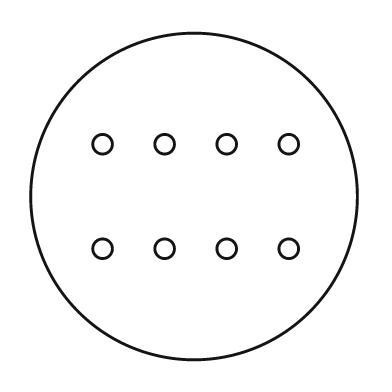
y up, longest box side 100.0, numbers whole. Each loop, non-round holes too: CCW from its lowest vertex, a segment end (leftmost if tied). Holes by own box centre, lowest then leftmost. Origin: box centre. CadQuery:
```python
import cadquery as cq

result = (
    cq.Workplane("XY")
    .moveTo(0.0, 0.0)
    .circle(50.0)
    .moveTo(-28.0, -16.0)
    .circle(3.0)
    .moveTo(-9.0, -16.0)
    .circle(3.0)
    .moveTo(10.0, -16.0)
    .circle(3.0)
    .moveTo(29.0, -16.0)
    .circle(3.0)
    .moveTo(-28.0, 16.0)
    .circle(3.0)
    .moveTo(-9.0, 16.0)
    .circle(3.0)
    .moveTo(10.0, 16.0)
    .circle(3.0)
    .moveTo(29.0, 16.0)
    .circle(3.0)
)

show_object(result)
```